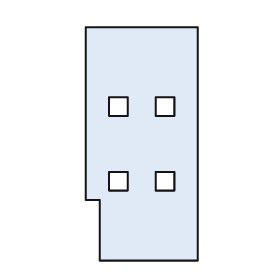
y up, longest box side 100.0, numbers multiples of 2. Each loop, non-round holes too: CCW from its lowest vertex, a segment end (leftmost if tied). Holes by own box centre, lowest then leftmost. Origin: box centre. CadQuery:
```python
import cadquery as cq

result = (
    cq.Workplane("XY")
    .moveTo(-18.0, -50.0)
    .lineTo(24.0, -50.0)
    .lineTo(24.0, 50.0)
    .lineTo(-24.0, 50.0)
    .lineTo(-24.0, -24.0)
    .lineTo(-18.0, -24.0)
    .close()
    .moveTo(-14.0, -20.0)
    .lineTo(-6.0, -20.0)
    .lineTo(-6.0, -12.0)
    .lineTo(-14.0, -12.0)
    .close()
    .moveTo(6.0, -20.0)
    .lineTo(14.0, -20.0)
    .lineTo(14.0, -12.0)
    .lineTo(6.0, -12.0)
    .close()
    .moveTo(-14.0, 12.0)
    .lineTo(-6.0, 12.0)
    .lineTo(-6.0, 20.0)
    .lineTo(-14.0, 20.0)
    .close()
    .moveTo(6.0, 12.0)
    .lineTo(14.0, 12.0)
    .lineTo(14.0, 20.0)
    .lineTo(6.0, 20.0)
    .close()
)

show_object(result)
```